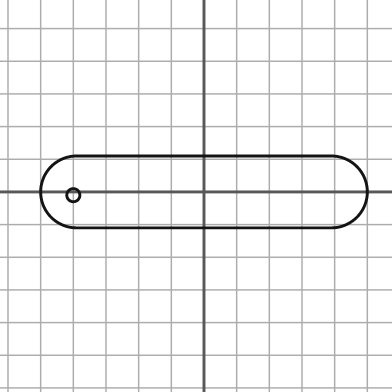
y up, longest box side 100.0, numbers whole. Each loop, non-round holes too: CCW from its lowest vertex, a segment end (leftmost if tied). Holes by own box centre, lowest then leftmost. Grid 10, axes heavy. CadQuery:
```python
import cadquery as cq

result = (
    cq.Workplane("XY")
    .moveTo(-39.0, -11.0)
    .lineTo(39.0, -11.0)
    .threePointArc((50.0, 0.0), (39.0, 11.0))
    .lineTo(-39.0, 11.0)
    .threePointArc((-50.0, 0.0), (-39.0, -11.0))
    .close()
    .moveTo(-40.0, -1.0)
    .circle(2.0)
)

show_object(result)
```